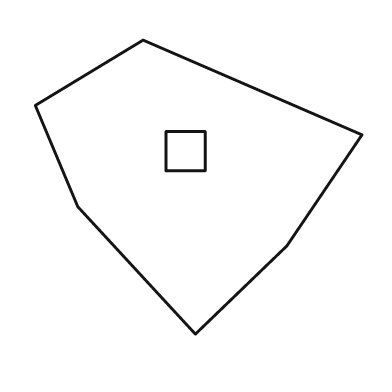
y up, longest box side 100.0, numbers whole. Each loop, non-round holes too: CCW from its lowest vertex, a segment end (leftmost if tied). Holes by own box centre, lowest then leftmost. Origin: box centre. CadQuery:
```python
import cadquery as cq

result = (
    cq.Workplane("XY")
    .moveTo(-1.0, -45.0)
    .lineTo(27.0, -18.0)
    .lineTo(50.0, 16.0)
    .lineTo(-17.0, 45.0)
    .lineTo(-50.0, 25.0)
    .lineTo(-37.0, -6.0)
    .close()
    .moveTo(-10.0, 5.0)
    .lineTo(2.0, 5.0)
    .lineTo(2.0, 17.0)
    .lineTo(-10.0, 17.0)
    .close()
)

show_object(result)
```